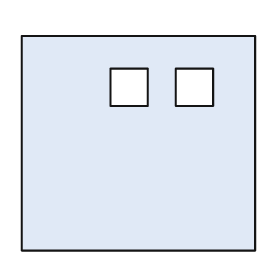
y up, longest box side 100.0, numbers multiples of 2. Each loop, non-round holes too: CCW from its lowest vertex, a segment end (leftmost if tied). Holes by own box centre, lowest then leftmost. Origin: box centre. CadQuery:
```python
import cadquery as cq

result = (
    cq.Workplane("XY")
    .moveTo(-50.0, -46.0)
    .lineTo(50.0, -46.0)
    .lineTo(50.0, 46.0)
    .lineTo(-50.0, 46.0)
    .close()
    .moveTo(-12.0, 16.0)
    .lineTo(4.0, 16.0)
    .lineTo(4.0, 32.0)
    .lineTo(-12.0, 32.0)
    .close()
    .moveTo(16.0, 16.0)
    .lineTo(32.0, 16.0)
    .lineTo(32.0, 32.0)
    .lineTo(16.0, 32.0)
    .close()
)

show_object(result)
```